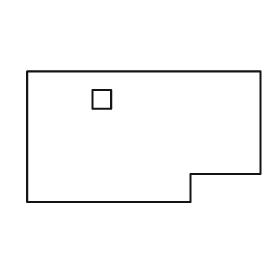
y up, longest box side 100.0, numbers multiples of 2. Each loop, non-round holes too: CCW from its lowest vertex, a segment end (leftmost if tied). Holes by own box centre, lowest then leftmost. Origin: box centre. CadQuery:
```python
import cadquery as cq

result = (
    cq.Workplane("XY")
    .moveTo(-50.0, -28.0)
    .lineTo(20.0, -28.0)
    .lineTo(20.0, -16.0)
    .lineTo(50.0, -16.0)
    .lineTo(50.0, 28.0)
    .lineTo(-50.0, 28.0)
    .close()
    .moveTo(-22.0, 12.0)
    .lineTo(-14.0, 12.0)
    .lineTo(-14.0, 20.0)
    .lineTo(-22.0, 20.0)
    .close()
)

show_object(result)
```